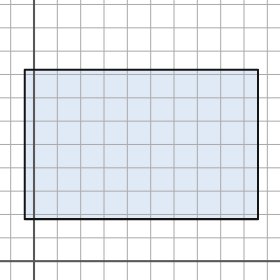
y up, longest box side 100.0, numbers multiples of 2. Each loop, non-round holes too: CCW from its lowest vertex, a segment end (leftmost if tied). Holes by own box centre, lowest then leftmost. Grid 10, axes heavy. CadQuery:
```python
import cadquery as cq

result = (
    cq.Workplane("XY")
    .moveTo(-4.0, 18.0)
    .lineTo(96.0, 18.0)
    .lineTo(96.0, 82.0)
    .lineTo(-4.0, 82.0)
    .close()
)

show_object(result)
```